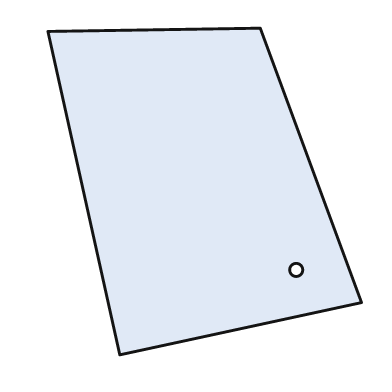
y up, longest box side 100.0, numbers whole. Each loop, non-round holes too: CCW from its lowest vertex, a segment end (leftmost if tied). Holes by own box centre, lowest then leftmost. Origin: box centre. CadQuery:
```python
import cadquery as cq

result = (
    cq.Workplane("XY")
    .moveTo(-26.0, -50.0)
    .lineTo(48.0, -34.0)
    .lineTo(17.0, 50.0)
    .lineTo(-48.0, 49.0)
    .close()
    .moveTo(28.0, -24.0)
    .circle(2.0)
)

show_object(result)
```